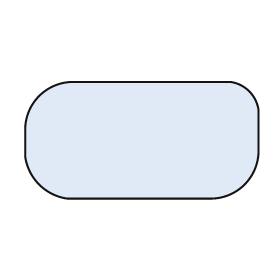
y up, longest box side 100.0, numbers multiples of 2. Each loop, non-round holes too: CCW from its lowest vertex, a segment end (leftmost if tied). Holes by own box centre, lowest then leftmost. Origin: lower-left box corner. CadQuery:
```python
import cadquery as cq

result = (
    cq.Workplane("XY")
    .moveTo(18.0, 0.0)
    .lineTo(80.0, 0.0)
    .threePointArc((94.0, 6.0), (100.0, 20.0))
    .lineTo(100.0, 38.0)
    .threePointArc((96.0, 46.0), (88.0, 50.0))
    .lineTo(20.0, 50.0)
    .threePointArc((6.0, 44.0), (0.0, 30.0))
    .lineTo(0.0, 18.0)
    .threePointArc((6.0, 6.0), (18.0, 0.0))
    .close()
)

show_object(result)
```